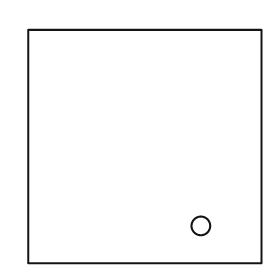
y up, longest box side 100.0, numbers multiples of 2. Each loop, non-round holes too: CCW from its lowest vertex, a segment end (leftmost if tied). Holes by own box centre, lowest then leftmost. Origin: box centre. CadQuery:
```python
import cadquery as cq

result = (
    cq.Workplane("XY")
    .moveTo(-50.0, -50.0)
    .lineTo(50.0, -50.0)
    .lineTo(50.0, 50.0)
    .lineTo(-50.0, 50.0)
    .close()
    .moveTo(24.0, -34.0)
    .circle(4.0)
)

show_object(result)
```